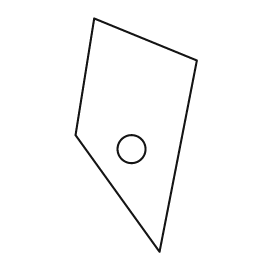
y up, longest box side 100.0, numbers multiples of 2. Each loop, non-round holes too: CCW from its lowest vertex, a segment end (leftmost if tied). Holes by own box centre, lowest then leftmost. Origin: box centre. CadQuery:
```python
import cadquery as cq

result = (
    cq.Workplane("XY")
    .moveTo(10.0, -50.0)
    .lineTo(26.0, 32.0)
    .lineTo(-18.0, 50.0)
    .lineTo(-26.0, 0.0)
    .close()
    .moveTo(-2.0, -6.0)
    .circle(6.0)
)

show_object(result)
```